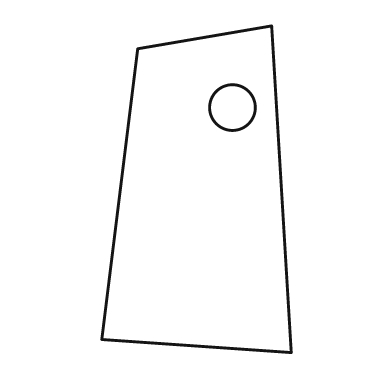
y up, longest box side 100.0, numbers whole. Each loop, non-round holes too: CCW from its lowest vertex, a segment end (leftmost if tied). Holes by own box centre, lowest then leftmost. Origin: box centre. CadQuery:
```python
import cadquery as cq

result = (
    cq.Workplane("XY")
    .moveTo(29.0, -50.0)
    .lineTo(23.0, 50.0)
    .lineTo(-18.0, 43.0)
    .lineTo(-29.0, -46.0)
    .close()
    .moveTo(11.0, 25.0)
    .circle(7.0)
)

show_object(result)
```